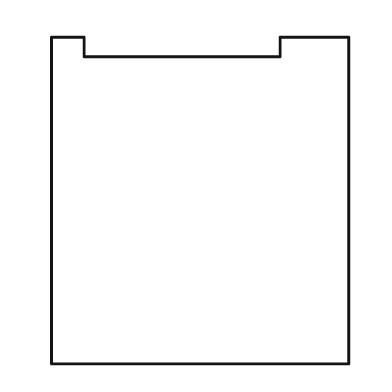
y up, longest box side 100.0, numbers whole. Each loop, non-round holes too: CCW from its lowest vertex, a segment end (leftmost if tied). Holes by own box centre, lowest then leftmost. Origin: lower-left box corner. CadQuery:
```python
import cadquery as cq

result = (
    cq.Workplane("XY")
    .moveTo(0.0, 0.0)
    .lineTo(91.0, 0.0)
    .lineTo(91.0, 100.0)
    .lineTo(70.0, 100.0)
    .lineTo(70.0, 94.0)
    .lineTo(10.0, 94.0)
    .lineTo(10.0, 100.0)
    .lineTo(0.0, 100.0)
    .close()
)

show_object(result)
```